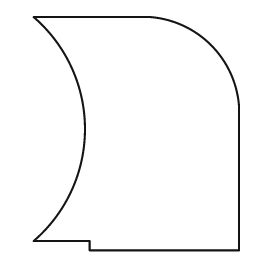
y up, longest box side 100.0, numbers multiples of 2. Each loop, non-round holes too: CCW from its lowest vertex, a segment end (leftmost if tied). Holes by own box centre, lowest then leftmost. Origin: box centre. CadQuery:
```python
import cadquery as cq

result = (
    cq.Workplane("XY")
    .moveTo(-20.0, -50.0)
    .lineTo(44.0, -50.0)
    .lineTo(44.0, 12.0)
    .threePointArc((32.0, 38.0), (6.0, 50.0))
    .lineTo(-44.0, 50.0)
    .threePointArc((-22.0, 2.0), (-44.0, -46.0))
    .lineTo(-20.0, -46.0)
    .close()
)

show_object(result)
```